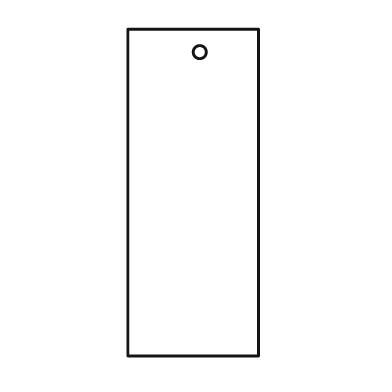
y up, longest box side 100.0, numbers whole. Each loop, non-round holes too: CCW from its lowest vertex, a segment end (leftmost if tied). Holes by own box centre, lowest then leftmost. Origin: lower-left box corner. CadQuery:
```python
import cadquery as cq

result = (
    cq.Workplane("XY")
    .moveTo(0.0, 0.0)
    .lineTo(40.0, 0.0)
    .lineTo(40.0, 100.0)
    .lineTo(0.0, 100.0)
    .close()
    .moveTo(22.0, 93.0)
    .circle(2.0)
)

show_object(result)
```